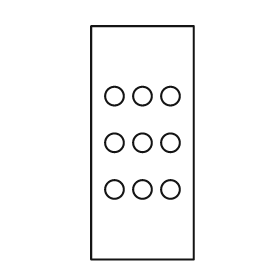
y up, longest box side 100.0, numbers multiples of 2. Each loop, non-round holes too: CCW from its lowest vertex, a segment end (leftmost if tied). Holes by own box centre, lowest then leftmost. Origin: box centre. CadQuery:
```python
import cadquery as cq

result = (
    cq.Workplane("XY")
    .moveTo(-22.0, -50.0)
    .lineTo(22.0, -50.0)
    .lineTo(22.0, 50.0)
    .lineTo(-22.0, 50.0)
    .close()
    .moveTo(-12.0, -20.0)
    .circle(4.0)
    .moveTo(0.0, -20.0)
    .circle(4.0)
    .moveTo(12.0, -20.0)
    .circle(4.0)
    .moveTo(-12.0, 0.0)
    .circle(4.0)
    .moveTo(0.0, 0.0)
    .circle(4.0)
    .moveTo(12.0, 0.0)
    .circle(4.0)
    .moveTo(-12.0, 20.0)
    .circle(4.0)
    .moveTo(0.0, 20.0)
    .circle(4.0)
    .moveTo(12.0, 20.0)
    .circle(4.0)
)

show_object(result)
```